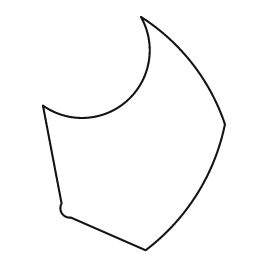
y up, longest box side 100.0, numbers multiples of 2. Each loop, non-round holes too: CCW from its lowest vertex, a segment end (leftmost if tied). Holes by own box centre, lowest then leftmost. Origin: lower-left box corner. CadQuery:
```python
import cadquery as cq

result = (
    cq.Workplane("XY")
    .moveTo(44.0, 0.0)
    .threePointArc((66.0, 24.0), (78.0, 54.0))
    .threePointArc((64.0, 80.0), (42.0, 100.0))
    .threePointArc((36.0, 64.0), (0.0, 62.0))
    .lineTo(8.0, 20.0)
    .threePointArc((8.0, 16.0), (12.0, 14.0))
    .close()
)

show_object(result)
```